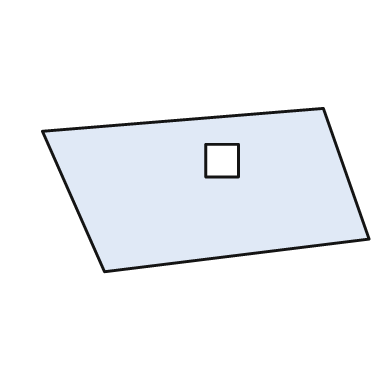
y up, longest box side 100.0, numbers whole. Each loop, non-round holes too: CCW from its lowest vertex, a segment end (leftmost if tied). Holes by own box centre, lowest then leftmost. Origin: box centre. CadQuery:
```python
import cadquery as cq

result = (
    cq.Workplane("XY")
    .moveTo(-31.0, -25.0)
    .lineTo(50.0, -15.0)
    .lineTo(36.0, 25.0)
    .lineTo(-50.0, 18.0)
    .close()
    .moveTo(0.0, 4.0)
    .lineTo(10.0, 4.0)
    .lineTo(10.0, 14.0)
    .lineTo(0.0, 14.0)
    .close()
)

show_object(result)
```